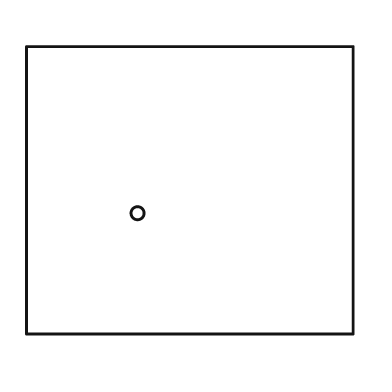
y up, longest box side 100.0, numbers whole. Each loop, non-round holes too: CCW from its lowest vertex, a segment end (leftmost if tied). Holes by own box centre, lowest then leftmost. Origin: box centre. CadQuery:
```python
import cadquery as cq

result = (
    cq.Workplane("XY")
    .moveTo(-50.0, -44.0)
    .lineTo(50.0, -44.0)
    .lineTo(50.0, 44.0)
    .lineTo(-50.0, 44.0)
    .close()
    .moveTo(-16.0, -7.0)
    .circle(2.0)
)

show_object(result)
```